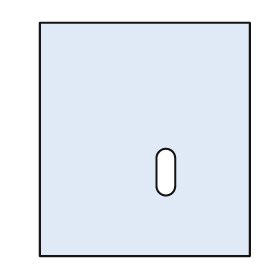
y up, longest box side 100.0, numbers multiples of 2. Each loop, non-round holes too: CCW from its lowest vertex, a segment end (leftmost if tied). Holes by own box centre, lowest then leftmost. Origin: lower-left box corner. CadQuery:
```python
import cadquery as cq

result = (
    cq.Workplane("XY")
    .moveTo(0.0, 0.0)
    .lineTo(90.0, 0.0)
    .lineTo(90.0, 100.0)
    .lineTo(0.0, 100.0)
    .close()
    .moveTo(50.0, 30.0)
    .threePointArc((54.0, 26.0), (58.0, 30.0))
    .lineTo(58.0, 42.0)
    .threePointArc((54.0, 46.0), (50.0, 42.0))
    .close()
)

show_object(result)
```